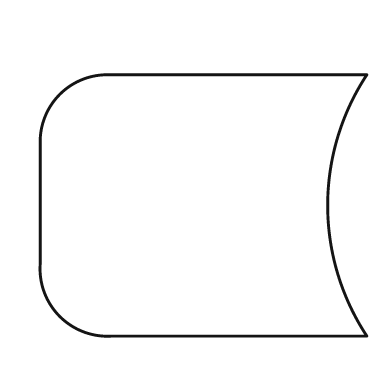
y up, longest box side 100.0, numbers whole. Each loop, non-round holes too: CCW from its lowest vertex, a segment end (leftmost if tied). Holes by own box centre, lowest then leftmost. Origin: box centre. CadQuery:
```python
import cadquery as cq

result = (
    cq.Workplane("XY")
    .moveTo(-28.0, -40.0)
    .lineTo(50.0, -40.0)
    .threePointArc((38.0, 0.0), (50.0, 40.0))
    .lineTo(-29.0, 40.0)
    .threePointArc((-44.0, 34.0), (-50.0, 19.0))
    .lineTo(-50.0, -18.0)
    .threePointArc((-44.0, -34.0), (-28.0, -40.0))
    .close()
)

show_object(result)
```